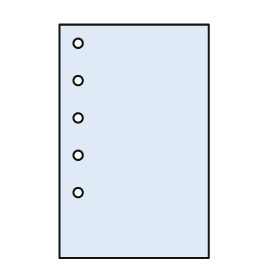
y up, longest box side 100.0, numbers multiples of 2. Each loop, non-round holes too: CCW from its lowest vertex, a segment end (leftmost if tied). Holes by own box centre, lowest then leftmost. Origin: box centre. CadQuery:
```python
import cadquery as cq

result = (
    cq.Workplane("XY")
    .moveTo(-32.0, -50.0)
    .lineTo(32.0, -50.0)
    .lineTo(32.0, 50.0)
    .lineTo(-32.0, 50.0)
    .close()
    .moveTo(-24.0, -22.0)
    .circle(2.0)
    .moveTo(-24.0, -6.0)
    .circle(2.0)
    .moveTo(-24.0, 10.0)
    .circle(2.0)
    .moveTo(-24.0, 26.0)
    .circle(2.0)
    .moveTo(-24.0, 42.0)
    .circle(2.0)
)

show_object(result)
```